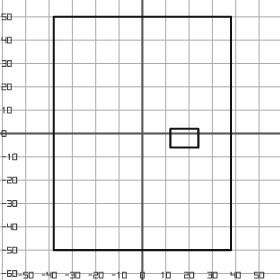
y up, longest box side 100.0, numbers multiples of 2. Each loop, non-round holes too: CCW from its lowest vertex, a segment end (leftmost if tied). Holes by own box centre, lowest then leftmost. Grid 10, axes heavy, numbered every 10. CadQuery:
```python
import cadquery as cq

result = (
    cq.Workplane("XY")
    .moveTo(-38.0, -50.0)
    .lineTo(38.0, -50.0)
    .lineTo(38.0, 50.0)
    .lineTo(-38.0, 50.0)
    .close()
    .moveTo(12.0, -6.0)
    .lineTo(24.0, -6.0)
    .lineTo(24.0, 2.0)
    .lineTo(12.0, 2.0)
    .close()
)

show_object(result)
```